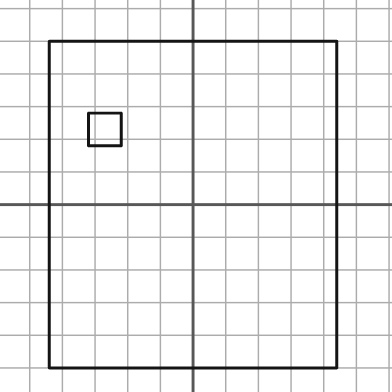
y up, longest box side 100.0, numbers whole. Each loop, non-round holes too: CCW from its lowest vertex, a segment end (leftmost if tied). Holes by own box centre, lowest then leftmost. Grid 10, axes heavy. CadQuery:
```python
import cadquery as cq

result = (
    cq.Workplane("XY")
    .moveTo(-44.0, -50.0)
    .lineTo(44.0, -50.0)
    .lineTo(44.0, 50.0)
    .lineTo(-44.0, 50.0)
    .close()
    .moveTo(-32.0, 18.0)
    .lineTo(-22.0, 18.0)
    .lineTo(-22.0, 28.0)
    .lineTo(-32.0, 28.0)
    .close()
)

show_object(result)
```